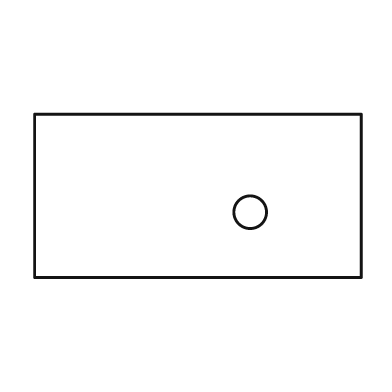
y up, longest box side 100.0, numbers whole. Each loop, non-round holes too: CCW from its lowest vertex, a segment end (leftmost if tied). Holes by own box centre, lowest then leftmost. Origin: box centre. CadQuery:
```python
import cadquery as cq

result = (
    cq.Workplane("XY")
    .moveTo(-50.0, -25.0)
    .lineTo(50.0, -25.0)
    .lineTo(50.0, 25.0)
    .lineTo(-50.0, 25.0)
    .close()
    .moveTo(16.0, -5.0)
    .circle(5.0)
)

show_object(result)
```